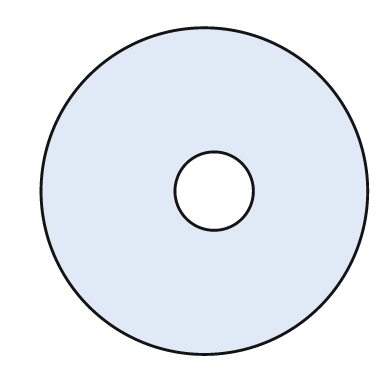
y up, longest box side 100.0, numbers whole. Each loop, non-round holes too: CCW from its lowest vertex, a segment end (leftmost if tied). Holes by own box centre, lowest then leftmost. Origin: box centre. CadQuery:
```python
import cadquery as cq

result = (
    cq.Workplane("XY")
    .moveTo(0.0, 0.0)
    .circle(50.0)
    .moveTo(3.0, 0.0)
    .circle(12.0)
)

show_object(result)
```